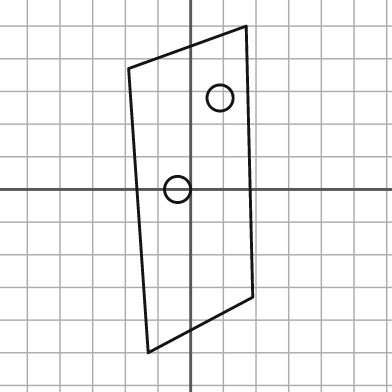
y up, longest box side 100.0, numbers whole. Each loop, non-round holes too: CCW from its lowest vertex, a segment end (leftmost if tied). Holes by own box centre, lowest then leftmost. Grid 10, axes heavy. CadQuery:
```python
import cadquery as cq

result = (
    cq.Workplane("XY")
    .moveTo(-13.0, -50.0)
    .lineTo(19.0, -33.0)
    .lineTo(17.0, 50.0)
    .lineTo(-19.0, 37.0)
    .close()
    .moveTo(-4.0, 0.0)
    .circle(4.0)
    .moveTo(9.0, 28.0)
    .circle(4.0)
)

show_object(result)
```